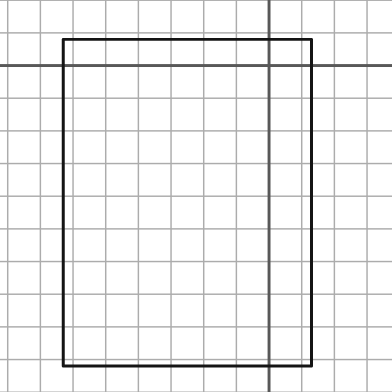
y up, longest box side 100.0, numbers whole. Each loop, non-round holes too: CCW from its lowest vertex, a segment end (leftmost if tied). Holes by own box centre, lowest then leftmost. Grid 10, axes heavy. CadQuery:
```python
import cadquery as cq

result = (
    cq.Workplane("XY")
    .moveTo(-63.0, -92.0)
    .lineTo(13.0, -92.0)
    .lineTo(13.0, 8.0)
    .lineTo(-63.0, 8.0)
    .close()
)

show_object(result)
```